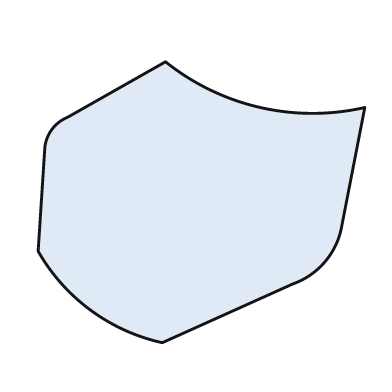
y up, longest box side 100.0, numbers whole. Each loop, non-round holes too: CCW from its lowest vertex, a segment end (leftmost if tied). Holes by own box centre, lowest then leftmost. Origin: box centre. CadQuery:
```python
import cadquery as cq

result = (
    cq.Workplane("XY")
    .moveTo(-12.0, -43.0)
    .lineTo(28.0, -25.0)
    .threePointArc((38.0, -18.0), (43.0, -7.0))
    .lineTo(50.0, 29.0)
    .threePointArc((18.0, 29.0), (-11.0, 43.0))
    .lineTo(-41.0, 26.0)
    .threePointArc((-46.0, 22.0), (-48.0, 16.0))
    .lineTo(-50.0, -15.0)
    .threePointArc((-34.0, -33.0), (-12.0, -43.0))
    .close()
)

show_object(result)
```